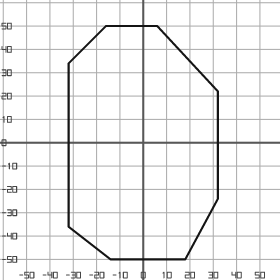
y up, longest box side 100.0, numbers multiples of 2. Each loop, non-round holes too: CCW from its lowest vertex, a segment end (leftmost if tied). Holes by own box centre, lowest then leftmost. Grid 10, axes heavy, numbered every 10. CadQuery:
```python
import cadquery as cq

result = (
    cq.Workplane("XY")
    .moveTo(-14.0, -50.0)
    .lineTo(18.0, -50.0)
    .lineTo(32.0, -24.0)
    .lineTo(32.0, 22.0)
    .lineTo(6.0, 50.0)
    .lineTo(-16.0, 50.0)
    .lineTo(-32.0, 34.0)
    .lineTo(-32.0, -36.0)
    .close()
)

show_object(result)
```